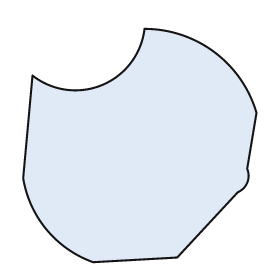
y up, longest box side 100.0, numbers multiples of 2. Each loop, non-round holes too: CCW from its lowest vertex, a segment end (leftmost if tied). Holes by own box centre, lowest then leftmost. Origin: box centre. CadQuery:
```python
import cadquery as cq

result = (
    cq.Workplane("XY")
    .moveTo(-20.0, -50.0)
    .lineTo(16.0, -48.0)
    .lineTo(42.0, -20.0)
    .threePointArc((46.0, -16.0), (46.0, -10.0))
    .lineTo(50.0, 14.0)
    .threePointArc((32.0, 40.0), (2.0, 50.0))
    .threePointArc((-16.0, 26.0), (-46.0, 30.0))
    .lineTo(-50.0, -14.0)
    .threePointArc((-40.0, -36.0), (-20.0, -50.0))
    .close()
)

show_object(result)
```